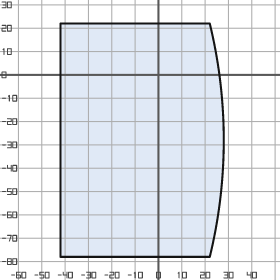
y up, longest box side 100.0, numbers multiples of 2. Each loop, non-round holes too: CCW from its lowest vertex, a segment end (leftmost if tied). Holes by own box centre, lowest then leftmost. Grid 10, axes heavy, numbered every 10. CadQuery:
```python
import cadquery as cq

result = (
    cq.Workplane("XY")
    .moveTo(-42.0, -78.0)
    .lineTo(22.0, -78.0)
    .threePointArc((28.0, -28.0), (22.0, 22.0))
    .lineTo(-42.0, 22.0)
    .close()
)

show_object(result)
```